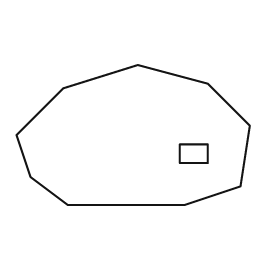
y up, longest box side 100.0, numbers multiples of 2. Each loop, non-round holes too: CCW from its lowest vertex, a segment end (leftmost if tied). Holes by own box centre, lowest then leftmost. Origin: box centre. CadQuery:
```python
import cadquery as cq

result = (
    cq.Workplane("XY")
    .moveTo(-28.0, -30.0)
    .lineTo(22.0, -30.0)
    .lineTo(46.0, -22.0)
    .lineTo(50.0, 4.0)
    .lineTo(32.0, 22.0)
    .lineTo(2.0, 30.0)
    .lineTo(-30.0, 20.0)
    .lineTo(-50.0, 0.0)
    .lineTo(-44.0, -18.0)
    .close()
    .moveTo(20.0, -12.0)
    .lineTo(32.0, -12.0)
    .lineTo(32.0, -4.0)
    .lineTo(20.0, -4.0)
    .close()
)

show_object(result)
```